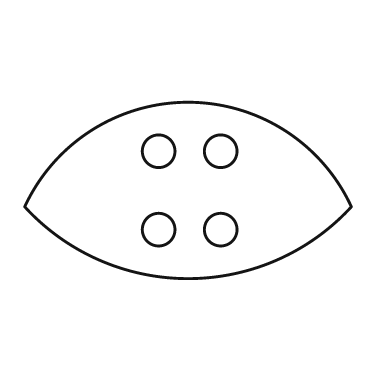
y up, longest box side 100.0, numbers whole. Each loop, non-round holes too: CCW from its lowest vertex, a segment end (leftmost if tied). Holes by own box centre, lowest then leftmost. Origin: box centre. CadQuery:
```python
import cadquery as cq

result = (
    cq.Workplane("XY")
    .moveTo(-50.0, -5.0)
    .threePointArc((0.0, -27.0), (50.0, -5.0))
    .threePointArc((0.0, 27.0), (-50.0, -5.0))
    .close()
    .moveTo(-9.0, -12.0)
    .circle(5.0)
    .moveTo(10.0, -12.0)
    .circle(5.0)
    .moveTo(-9.0, 12.0)
    .circle(5.0)
    .moveTo(10.0, 12.0)
    .circle(5.0)
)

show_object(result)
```